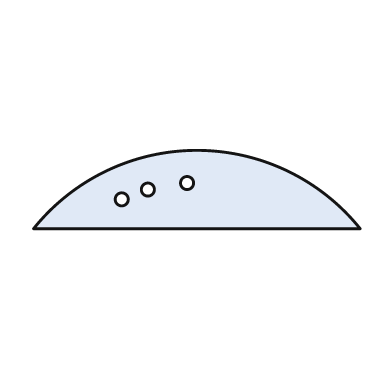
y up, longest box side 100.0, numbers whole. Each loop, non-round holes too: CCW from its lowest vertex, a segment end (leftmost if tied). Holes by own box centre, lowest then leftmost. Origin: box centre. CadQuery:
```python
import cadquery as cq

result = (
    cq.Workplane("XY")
    .moveTo(-50.0, -12.0)
    .lineTo(50.0, -12.0)
    .threePointArc((0.0, 12.0), (-50.0, -12.0))
    .close()
    .moveTo(-23.0, -3.0)
    .circle(2.0)
    .moveTo(-15.0, 0.0)
    .circle(2.0)
    .moveTo(-3.0, 2.0)
    .circle(2.0)
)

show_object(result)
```